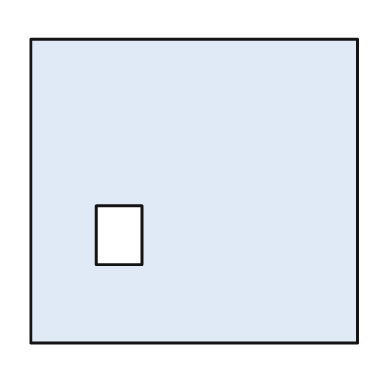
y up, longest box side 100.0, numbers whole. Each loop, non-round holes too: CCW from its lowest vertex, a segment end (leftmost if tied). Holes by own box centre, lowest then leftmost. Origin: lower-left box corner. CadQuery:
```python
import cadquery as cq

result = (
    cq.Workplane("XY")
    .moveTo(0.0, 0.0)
    .lineTo(100.0, 0.0)
    .lineTo(100.0, 93.0)
    .lineTo(0.0, 93.0)
    .close()
    .moveTo(20.0, 24.0)
    .lineTo(34.0, 24.0)
    .lineTo(34.0, 42.0)
    .lineTo(20.0, 42.0)
    .close()
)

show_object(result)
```